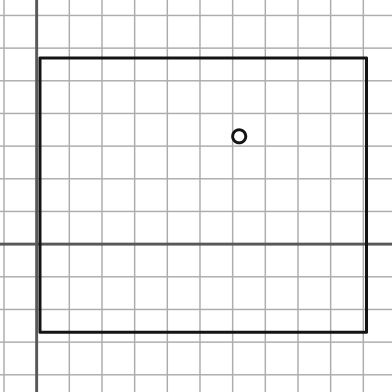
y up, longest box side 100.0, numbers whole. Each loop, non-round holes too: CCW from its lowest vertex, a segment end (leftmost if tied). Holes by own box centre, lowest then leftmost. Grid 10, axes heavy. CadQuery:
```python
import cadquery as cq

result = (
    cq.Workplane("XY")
    .moveTo(1.0, -27.0)
    .lineTo(101.0, -27.0)
    .lineTo(101.0, 57.0)
    .lineTo(1.0, 57.0)
    .close()
    .moveTo(62.0, 33.0)
    .circle(2.0)
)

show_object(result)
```